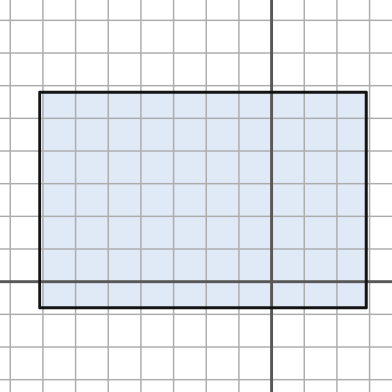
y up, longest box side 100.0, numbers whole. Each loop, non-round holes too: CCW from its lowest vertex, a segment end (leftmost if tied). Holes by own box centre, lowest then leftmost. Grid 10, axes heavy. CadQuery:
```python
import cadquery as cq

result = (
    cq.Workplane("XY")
    .moveTo(-71.0, -8.0)
    .lineTo(29.0, -8.0)
    .lineTo(29.0, 58.0)
    .lineTo(-71.0, 58.0)
    .close()
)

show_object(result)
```